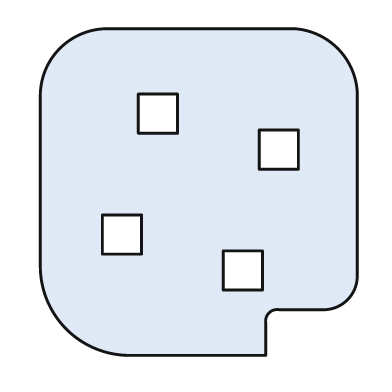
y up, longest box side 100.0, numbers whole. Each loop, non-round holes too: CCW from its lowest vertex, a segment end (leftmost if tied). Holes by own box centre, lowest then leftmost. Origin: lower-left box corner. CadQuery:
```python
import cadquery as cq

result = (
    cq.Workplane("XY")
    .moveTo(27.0, 0.0)
    .lineTo(69.0, 0.0)
    .lineTo(69.0, 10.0)
    .threePointArc((70.0, 13.0), (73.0, 14.0))
    .lineTo(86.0, 14.0)
    .threePointArc((94.0, 17.0), (97.0, 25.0))
    .lineTo(97.0, 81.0)
    .threePointArc((91.0, 94.0), (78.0, 100.0))
    .lineTo(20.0, 100.0)
    .threePointArc((6.0, 94.0), (0.0, 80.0))
    .lineTo(0.0, 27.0)
    .threePointArc((8.0, 8.0), (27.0, 0.0))
    .close()
    .moveTo(56.0, 20.0)
    .lineTo(68.0, 20.0)
    .lineTo(68.0, 32.0)
    .lineTo(56.0, 32.0)
    .close()
    .moveTo(19.0, 31.0)
    .lineTo(31.0, 31.0)
    .lineTo(31.0, 43.0)
    .lineTo(19.0, 43.0)
    .close()
    .moveTo(67.0, 57.0)
    .lineTo(79.0, 57.0)
    .lineTo(79.0, 69.0)
    .lineTo(67.0, 69.0)
    .close()
    .moveTo(30.0, 68.0)
    .lineTo(42.0, 68.0)
    .lineTo(42.0, 80.0)
    .lineTo(30.0, 80.0)
    .close()
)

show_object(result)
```